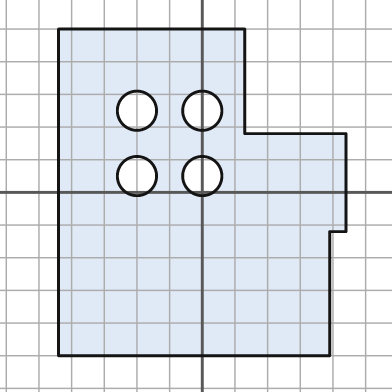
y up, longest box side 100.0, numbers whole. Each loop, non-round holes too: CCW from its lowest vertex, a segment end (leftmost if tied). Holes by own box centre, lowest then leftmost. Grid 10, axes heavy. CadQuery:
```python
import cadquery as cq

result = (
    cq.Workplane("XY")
    .moveTo(-44.0, -50.0)
    .lineTo(39.0, -50.0)
    .lineTo(39.0, -12.0)
    .lineTo(44.0, -12.0)
    .lineTo(44.0, 18.0)
    .lineTo(13.0, 18.0)
    .lineTo(13.0, 50.0)
    .lineTo(-44.0, 50.0)
    .close()
    .moveTo(-20.0, 5.0)
    .circle(6.0)
    .moveTo(0.0, 5.0)
    .circle(6.0)
    .moveTo(-20.0, 25.0)
    .circle(6.0)
    .moveTo(0.0, 25.0)
    .circle(6.0)
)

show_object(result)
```